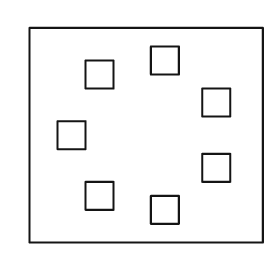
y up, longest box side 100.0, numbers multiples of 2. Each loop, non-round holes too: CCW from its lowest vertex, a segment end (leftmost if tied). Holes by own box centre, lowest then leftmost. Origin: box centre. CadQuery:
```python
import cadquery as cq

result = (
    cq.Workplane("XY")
    .moveTo(-50.0, -46.0)
    .lineTo(50.0, -46.0)
    .lineTo(50.0, 46.0)
    .lineTo(-50.0, 46.0)
    .close()
    .moveTo(2.0, -38.0)
    .lineTo(14.0, -38.0)
    .lineTo(14.0, -26.0)
    .lineTo(2.0, -26.0)
    .close()
    .moveTo(-26.0, -32.0)
    .lineTo(-14.0, -32.0)
    .lineTo(-14.0, -20.0)
    .lineTo(-26.0, -20.0)
    .close()
    .moveTo(24.0, -20.0)
    .lineTo(36.0, -20.0)
    .lineTo(36.0, -8.0)
    .lineTo(24.0, -8.0)
    .close()
    .moveTo(-38.0, -6.0)
    .lineTo(-26.0, -6.0)
    .lineTo(-26.0, 6.0)
    .lineTo(-38.0, 6.0)
    .close()
    .moveTo(24.0, 8.0)
    .lineTo(36.0, 8.0)
    .lineTo(36.0, 20.0)
    .lineTo(24.0, 20.0)
    .close()
    .moveTo(-26.0, 20.0)
    .lineTo(-14.0, 20.0)
    .lineTo(-14.0, 32.0)
    .lineTo(-26.0, 32.0)
    .close()
    .moveTo(2.0, 26.0)
    .lineTo(14.0, 26.0)
    .lineTo(14.0, 38.0)
    .lineTo(2.0, 38.0)
    .close()
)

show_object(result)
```